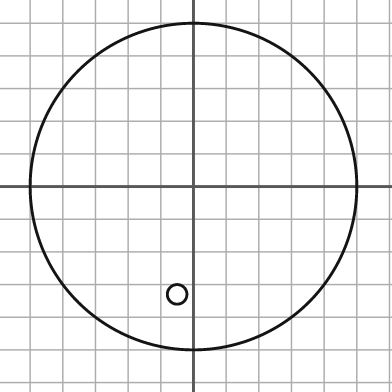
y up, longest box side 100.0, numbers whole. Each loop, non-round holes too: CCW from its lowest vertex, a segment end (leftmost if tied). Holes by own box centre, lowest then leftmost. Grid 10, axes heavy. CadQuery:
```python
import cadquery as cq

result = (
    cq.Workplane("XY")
    .moveTo(0.0, 0.0)
    .circle(50.0)
    .moveTo(-5.0, -33.0)
    .circle(3.0)
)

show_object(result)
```